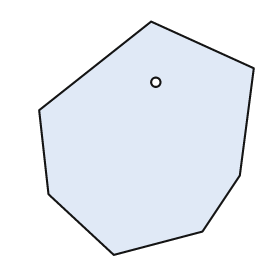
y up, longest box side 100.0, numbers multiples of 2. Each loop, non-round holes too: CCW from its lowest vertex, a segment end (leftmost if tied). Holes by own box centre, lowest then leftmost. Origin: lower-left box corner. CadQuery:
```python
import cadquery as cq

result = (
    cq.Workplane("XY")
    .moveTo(32.0, 0.0)
    .lineTo(70.0, 10.0)
    .lineTo(86.0, 34.0)
    .lineTo(92.0, 80.0)
    .lineTo(48.0, 100.0)
    .lineTo(0.0, 62.0)
    .lineTo(4.0, 26.0)
    .close()
    .moveTo(50.0, 74.0)
    .circle(2.0)
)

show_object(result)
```